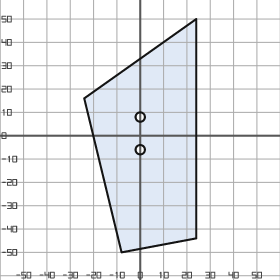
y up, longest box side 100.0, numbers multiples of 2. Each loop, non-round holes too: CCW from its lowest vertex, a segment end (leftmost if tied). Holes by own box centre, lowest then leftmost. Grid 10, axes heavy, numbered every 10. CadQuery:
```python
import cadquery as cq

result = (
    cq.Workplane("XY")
    .moveTo(-8.0, -50.0)
    .lineTo(24.0, -44.0)
    .lineTo(24.0, 50.0)
    .lineTo(-24.0, 16.0)
    .close()
    .moveTo(0.0, -6.0)
    .circle(2.0)
    .moveTo(0.0, 8.0)
    .circle(2.0)
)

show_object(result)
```